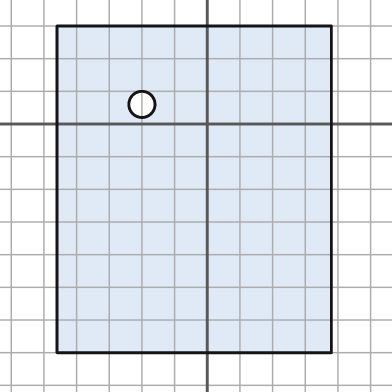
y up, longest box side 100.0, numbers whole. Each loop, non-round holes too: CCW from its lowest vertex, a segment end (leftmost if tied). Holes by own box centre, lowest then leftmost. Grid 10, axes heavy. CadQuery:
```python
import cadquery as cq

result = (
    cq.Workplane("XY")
    .moveTo(-46.0, -70.0)
    .lineTo(38.0, -70.0)
    .lineTo(38.0, 30.0)
    .lineTo(-46.0, 30.0)
    .close()
    .moveTo(-20.0, 6.0)
    .circle(4.0)
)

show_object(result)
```